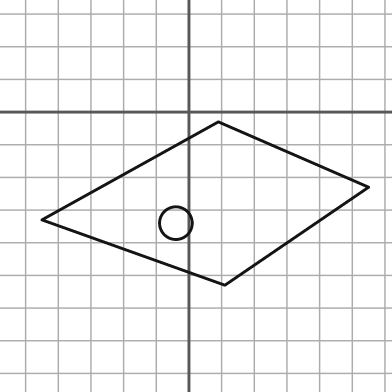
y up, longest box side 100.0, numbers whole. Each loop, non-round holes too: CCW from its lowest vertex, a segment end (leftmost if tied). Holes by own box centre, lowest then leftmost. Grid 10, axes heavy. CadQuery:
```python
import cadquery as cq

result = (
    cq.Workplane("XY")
    .moveTo(11.0, -53.0)
    .lineTo(55.0, -23.0)
    .lineTo(9.0, -3.0)
    .lineTo(-45.0, -33.0)
    .close()
    .moveTo(-4.0, -34.0)
    .circle(5.0)
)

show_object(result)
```